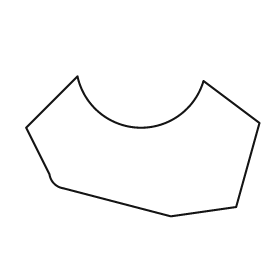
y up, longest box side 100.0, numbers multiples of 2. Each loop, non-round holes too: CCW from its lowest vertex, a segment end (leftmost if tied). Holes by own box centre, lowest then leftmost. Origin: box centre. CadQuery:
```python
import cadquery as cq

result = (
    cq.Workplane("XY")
    .moveTo(12.0, -30.0)
    .lineTo(40.0, -26.0)
    .lineTo(50.0, 10.0)
    .lineTo(26.0, 28.0)
    .threePointArc((-2.0, 8.0), (-28.0, 30.0))
    .lineTo(-50.0, 8.0)
    .lineTo(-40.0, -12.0)
    .threePointArc((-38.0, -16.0), (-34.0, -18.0))
    .close()
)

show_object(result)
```